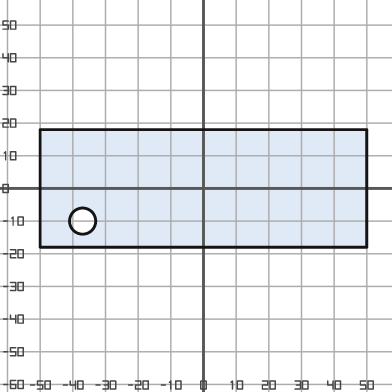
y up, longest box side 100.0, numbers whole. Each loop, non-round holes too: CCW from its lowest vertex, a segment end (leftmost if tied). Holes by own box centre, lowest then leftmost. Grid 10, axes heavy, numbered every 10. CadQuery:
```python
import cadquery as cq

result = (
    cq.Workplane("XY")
    .moveTo(-50.0, -18.0)
    .lineTo(50.0, -18.0)
    .lineTo(50.0, 18.0)
    .lineTo(-50.0, 18.0)
    .close()
    .moveTo(-37.0, -10.0)
    .circle(4.0)
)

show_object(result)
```